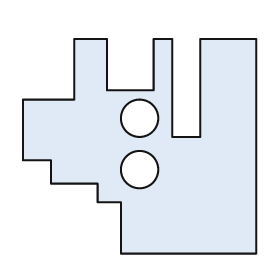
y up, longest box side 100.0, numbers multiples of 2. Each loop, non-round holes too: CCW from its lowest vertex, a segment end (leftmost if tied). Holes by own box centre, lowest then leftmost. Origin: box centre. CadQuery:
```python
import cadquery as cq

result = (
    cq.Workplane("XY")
    .moveTo(-8.0, -46.0)
    .lineTo(50.0, -46.0)
    .lineTo(50.0, 46.0)
    .lineTo(26.0, 46.0)
    .lineTo(26.0, 4.0)
    .lineTo(14.0, 4.0)
    .lineTo(14.0, 46.0)
    .lineTo(6.0, 46.0)
    .lineTo(6.0, 24.0)
    .lineTo(-14.0, 24.0)
    .lineTo(-14.0, 46.0)
    .lineTo(-28.0, 46.0)
    .lineTo(-28.0, 20.0)
    .lineTo(-50.0, 20.0)
    .lineTo(-50.0, -6.0)
    .lineTo(-38.0, -6.0)
    .lineTo(-38.0, -16.0)
    .lineTo(-18.0, -16.0)
    .lineTo(-18.0, -24.0)
    .lineTo(-8.0, -24.0)
    .close()
    .moveTo(0.0, -10.0)
    .circle(8.0)
    .moveTo(0.0, 12.0)
    .circle(8.0)
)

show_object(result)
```